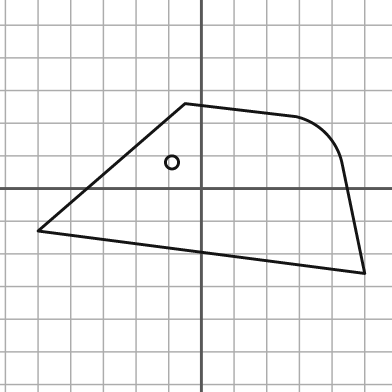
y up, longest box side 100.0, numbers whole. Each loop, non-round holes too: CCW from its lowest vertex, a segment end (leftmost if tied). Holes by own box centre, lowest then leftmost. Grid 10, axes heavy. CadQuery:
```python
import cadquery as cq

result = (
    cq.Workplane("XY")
    .moveTo(50.0, -26.0)
    .lineTo(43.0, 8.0)
    .threePointArc((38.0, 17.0), (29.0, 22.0))
    .lineTo(-5.0, 26.0)
    .lineTo(-50.0, -13.0)
    .close()
    .moveTo(-9.0, 8.0)
    .circle(2.0)
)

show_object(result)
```